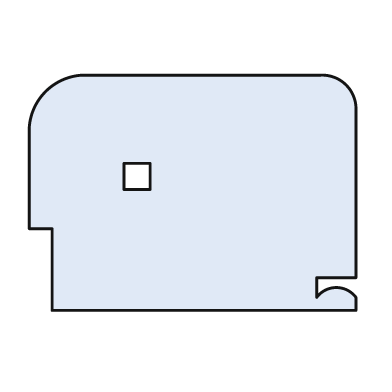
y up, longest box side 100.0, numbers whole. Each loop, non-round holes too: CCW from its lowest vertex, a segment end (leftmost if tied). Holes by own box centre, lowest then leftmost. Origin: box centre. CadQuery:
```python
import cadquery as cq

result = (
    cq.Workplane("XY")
    .moveTo(-43.0, -36.0)
    .lineTo(50.0, -36.0)
    .lineTo(50.0, -32.0)
    .threePointArc((44.0, -29.0), (38.0, -32.0))
    .lineTo(38.0, -26.0)
    .lineTo(50.0, -26.0)
    .lineTo(50.0, 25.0)
    .threePointArc((47.0, 33.0), (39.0, 36.0))
    .lineTo(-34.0, 36.0)
    .threePointArc((-45.0, 31.0), (-50.0, 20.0))
    .lineTo(-50.0, -11.0)
    .lineTo(-43.0, -11.0)
    .close()
    .moveTo(-21.0, 1.0)
    .lineTo(-13.0, 1.0)
    .lineTo(-13.0, 9.0)
    .lineTo(-21.0, 9.0)
    .close()
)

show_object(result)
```